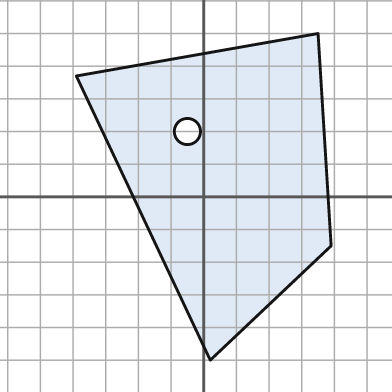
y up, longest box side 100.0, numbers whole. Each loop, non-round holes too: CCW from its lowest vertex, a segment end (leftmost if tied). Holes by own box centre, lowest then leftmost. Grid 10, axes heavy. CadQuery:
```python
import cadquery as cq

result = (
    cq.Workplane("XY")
    .moveTo(2.0, -50.0)
    .lineTo(39.0, -15.0)
    .lineTo(35.0, 50.0)
    .lineTo(-39.0, 37.0)
    .close()
    .moveTo(-5.0, 20.0)
    .circle(4.0)
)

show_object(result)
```